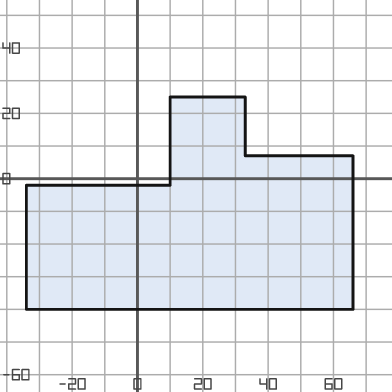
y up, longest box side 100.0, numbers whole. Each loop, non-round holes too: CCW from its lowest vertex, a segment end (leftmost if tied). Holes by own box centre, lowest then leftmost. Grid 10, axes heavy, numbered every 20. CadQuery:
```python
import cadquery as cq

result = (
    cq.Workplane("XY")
    .moveTo(-34.0, -40.0)
    .lineTo(66.0, -40.0)
    .lineTo(66.0, 7.0)
    .lineTo(33.0, 7.0)
    .lineTo(33.0, 25.0)
    .lineTo(10.0, 25.0)
    .lineTo(10.0, -2.0)
    .lineTo(-34.0, -2.0)
    .close()
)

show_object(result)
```